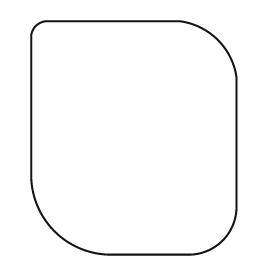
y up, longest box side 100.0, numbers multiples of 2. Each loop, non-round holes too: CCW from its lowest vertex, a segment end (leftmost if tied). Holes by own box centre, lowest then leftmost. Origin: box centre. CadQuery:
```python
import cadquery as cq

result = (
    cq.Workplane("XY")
    .moveTo(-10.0, -50.0)
    .lineTo(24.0, -50.0)
    .threePointArc((38.0, -44.0), (44.0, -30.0))
    .lineTo(44.0, 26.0)
    .threePointArc((36.0, 42.0), (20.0, 50.0))
    .lineTo(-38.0, 50.0)
    .threePointArc((-42.0, 48.0), (-44.0, 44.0))
    .lineTo(-44.0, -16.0)
    .threePointArc((-34.0, -40.0), (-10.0, -50.0))
    .close()
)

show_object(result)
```